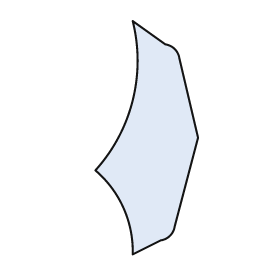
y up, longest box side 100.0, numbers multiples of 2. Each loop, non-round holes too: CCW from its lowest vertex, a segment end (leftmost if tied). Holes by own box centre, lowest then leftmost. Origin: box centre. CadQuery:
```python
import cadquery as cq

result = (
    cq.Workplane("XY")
    .moveTo(-6.0, -50.0)
    .lineTo(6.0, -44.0)
    .threePointArc((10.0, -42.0), (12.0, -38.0))
    .lineTo(22.0, 0.0)
    .lineTo(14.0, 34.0)
    .threePointArc((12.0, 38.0), (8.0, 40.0))
    .lineTo(-6.0, 50.0)
    .threePointArc((-6.0, 16.0), (-22.0, -14.0))
    .threePointArc((-10.0, -30.0), (-6.0, -50.0))
    .close()
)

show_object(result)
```